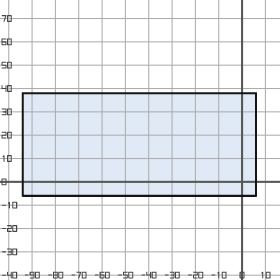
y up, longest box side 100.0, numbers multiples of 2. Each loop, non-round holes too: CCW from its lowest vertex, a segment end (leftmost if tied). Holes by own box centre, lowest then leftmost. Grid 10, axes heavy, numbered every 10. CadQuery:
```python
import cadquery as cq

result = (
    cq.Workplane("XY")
    .moveTo(-94.0, -6.0)
    .lineTo(6.0, -6.0)
    .lineTo(6.0, 38.0)
    .lineTo(-94.0, 38.0)
    .close()
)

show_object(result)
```